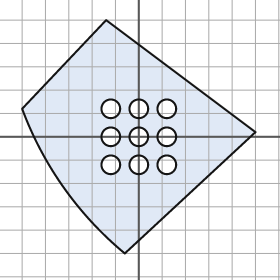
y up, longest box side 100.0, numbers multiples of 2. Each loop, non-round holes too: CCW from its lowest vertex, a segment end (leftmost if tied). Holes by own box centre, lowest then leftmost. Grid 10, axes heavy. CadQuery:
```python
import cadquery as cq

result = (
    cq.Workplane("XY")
    .moveTo(-6.0, -50.0)
    .lineTo(50.0, 2.0)
    .lineTo(-14.0, 50.0)
    .lineTo(-50.0, 12.0)
    .threePointArc((-32.0, -22.0), (-6.0, -50.0))
    .close()
    .moveTo(-12.0, -12.0)
    .circle(4.0)
    .moveTo(0.0, -12.0)
    .circle(4.0)
    .moveTo(12.0, -12.0)
    .circle(4.0)
    .moveTo(-12.0, 0.0)
    .circle(4.0)
    .moveTo(0.0, 0.0)
    .circle(4.0)
    .moveTo(12.0, 0.0)
    .circle(4.0)
    .moveTo(-12.0, 12.0)
    .circle(4.0)
    .moveTo(0.0, 12.0)
    .circle(4.0)
    .moveTo(12.0, 12.0)
    .circle(4.0)
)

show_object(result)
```